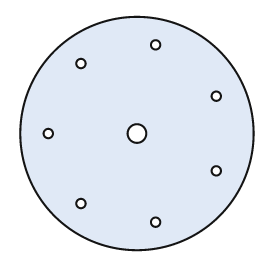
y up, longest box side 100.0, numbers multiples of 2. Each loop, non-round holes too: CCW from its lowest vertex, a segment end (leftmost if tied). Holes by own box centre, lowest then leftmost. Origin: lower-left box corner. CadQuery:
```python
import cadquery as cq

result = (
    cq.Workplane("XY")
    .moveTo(50.0, 50.0)
    .circle(50.0)
    .moveTo(58.0, 12.0)
    .circle(2.0)
    .moveTo(26.0, 20.0)
    .circle(2.0)
    .moveTo(84.0, 34.0)
    .circle(2.0)
    .moveTo(12.0, 50.0)
    .circle(2.0)
    .moveTo(50.0, 50.0)
    .circle(4.0)
    .moveTo(84.0, 66.0)
    .circle(2.0)
    .moveTo(26.0, 80.0)
    .circle(2.0)
    .moveTo(58.0, 88.0)
    .circle(2.0)
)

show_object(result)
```